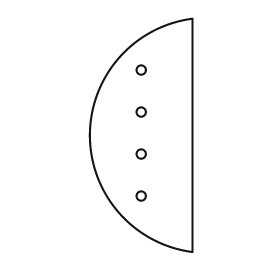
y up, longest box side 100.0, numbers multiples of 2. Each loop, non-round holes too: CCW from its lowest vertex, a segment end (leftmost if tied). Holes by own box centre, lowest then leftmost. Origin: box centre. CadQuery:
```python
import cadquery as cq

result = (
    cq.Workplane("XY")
    .moveTo(22.0, -50.0)
    .lineTo(22.0, 50.0)
    .threePointArc((-22.0, 0.0), (22.0, -50.0))
    .close()
    .moveTo(0.0, -26.0)
    .circle(2.0)
    .moveTo(0.0, -8.0)
    .circle(2.0)
    .moveTo(0.0, 10.0)
    .circle(2.0)
    .moveTo(0.0, 28.0)
    .circle(2.0)
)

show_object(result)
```